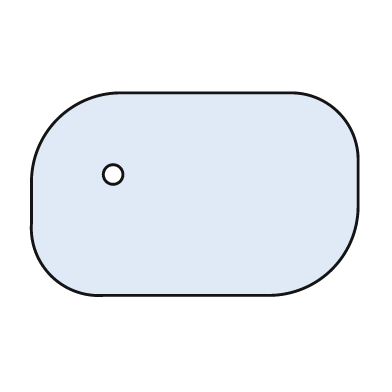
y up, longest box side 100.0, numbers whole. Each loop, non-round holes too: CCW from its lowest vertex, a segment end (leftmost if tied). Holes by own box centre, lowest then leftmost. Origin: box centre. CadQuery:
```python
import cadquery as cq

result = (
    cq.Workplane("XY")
    .moveTo(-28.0, -31.0)
    .lineTo(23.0, -31.0)
    .threePointArc((42.0, -23.0), (50.0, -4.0))
    .lineTo(50.0, 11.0)
    .threePointArc((44.0, 25.0), (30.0, 31.0))
    .lineTo(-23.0, 31.0)
    .threePointArc((-42.0, 23.0), (-50.0, 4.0))
    .lineTo(-50.0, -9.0)
    .threePointArc((-44.0, -25.0), (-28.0, -31.0))
    .close()
    .moveTo(-25.0, 6.0)
    .circle(3.0)
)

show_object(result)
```